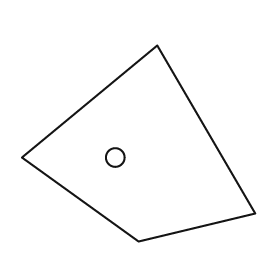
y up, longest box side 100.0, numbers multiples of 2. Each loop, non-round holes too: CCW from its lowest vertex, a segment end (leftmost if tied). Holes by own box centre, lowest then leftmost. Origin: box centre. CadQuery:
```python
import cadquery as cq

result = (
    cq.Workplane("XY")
    .moveTo(0.0, -42.0)
    .lineTo(50.0, -30.0)
    .lineTo(8.0, 42.0)
    .lineTo(-50.0, -6.0)
    .close()
    .moveTo(-10.0, -6.0)
    .circle(4.0)
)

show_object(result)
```